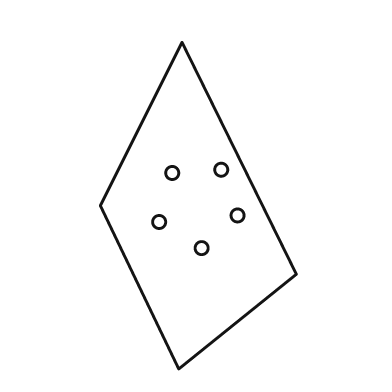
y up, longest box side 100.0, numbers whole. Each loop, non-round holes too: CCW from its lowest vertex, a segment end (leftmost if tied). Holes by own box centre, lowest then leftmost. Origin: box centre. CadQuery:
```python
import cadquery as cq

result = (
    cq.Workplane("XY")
    .moveTo(-6.0, -50.0)
    .lineTo(30.0, -21.0)
    .lineTo(-5.0, 50.0)
    .lineTo(-30.0, 0.0)
    .close()
    .moveTo(1.0, -13.0)
    .circle(2.0)
    .moveTo(-12.0, -5.0)
    .circle(2.0)
    .moveTo(12.0, -3.0)
    .circle(2.0)
    .moveTo(-8.0, 10.0)
    .circle(2.0)
    .moveTo(7.0, 11.0)
    .circle(2.0)
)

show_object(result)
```